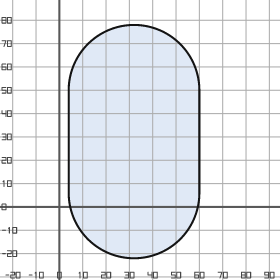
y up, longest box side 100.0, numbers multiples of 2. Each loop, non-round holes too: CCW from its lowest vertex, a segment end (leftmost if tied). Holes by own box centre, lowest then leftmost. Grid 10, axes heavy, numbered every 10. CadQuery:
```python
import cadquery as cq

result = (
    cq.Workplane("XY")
    .moveTo(4.0, 6.0)
    .threePointArc((32.0, -22.0), (60.0, 6.0))
    .lineTo(60.0, 50.0)
    .threePointArc((32.0, 78.0), (4.0, 50.0))
    .close()
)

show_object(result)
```